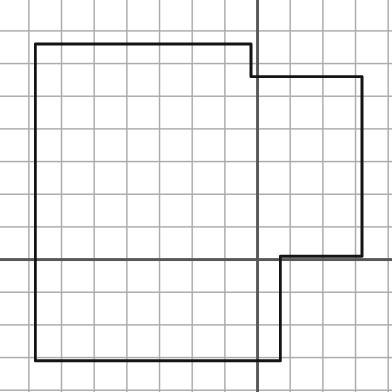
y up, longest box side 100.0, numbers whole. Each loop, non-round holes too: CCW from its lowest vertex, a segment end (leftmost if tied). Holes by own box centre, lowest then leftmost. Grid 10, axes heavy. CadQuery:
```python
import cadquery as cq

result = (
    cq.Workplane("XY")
    .moveTo(-68.0, -31.0)
    .lineTo(7.0, -31.0)
    .lineTo(7.0, 1.0)
    .lineTo(32.0, 1.0)
    .lineTo(32.0, 56.0)
    .lineTo(-2.0, 56.0)
    .lineTo(-2.0, 66.0)
    .lineTo(-68.0, 66.0)
    .close()
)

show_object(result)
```